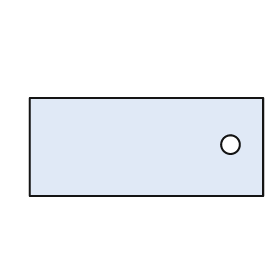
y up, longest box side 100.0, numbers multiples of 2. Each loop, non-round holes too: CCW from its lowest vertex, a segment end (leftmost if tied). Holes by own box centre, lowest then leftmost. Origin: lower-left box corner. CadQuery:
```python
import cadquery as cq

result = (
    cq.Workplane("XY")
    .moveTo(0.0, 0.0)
    .lineTo(100.0, 0.0)
    .lineTo(100.0, 42.0)
    .lineTo(0.0, 42.0)
    .close()
    .moveTo(86.0, 22.0)
    .circle(4.0)
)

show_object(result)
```